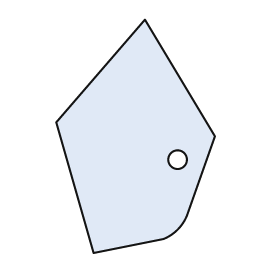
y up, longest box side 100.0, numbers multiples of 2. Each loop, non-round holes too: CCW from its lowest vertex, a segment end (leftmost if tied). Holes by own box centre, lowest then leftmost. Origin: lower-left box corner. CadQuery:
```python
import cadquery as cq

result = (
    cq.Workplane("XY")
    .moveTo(16.0, 0.0)
    .lineTo(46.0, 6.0)
    .threePointArc((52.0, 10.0), (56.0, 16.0))
    .lineTo(68.0, 50.0)
    .lineTo(38.0, 100.0)
    .lineTo(0.0, 56.0)
    .close()
    .moveTo(52.0, 40.0)
    .circle(4.0)
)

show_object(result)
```